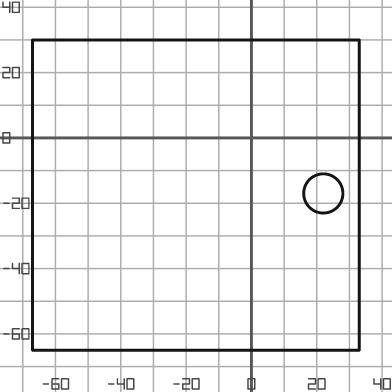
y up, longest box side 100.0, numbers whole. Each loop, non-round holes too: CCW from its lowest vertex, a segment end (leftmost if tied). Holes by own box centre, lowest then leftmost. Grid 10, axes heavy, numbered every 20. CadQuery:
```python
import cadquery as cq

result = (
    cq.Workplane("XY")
    .moveTo(-67.0, -65.0)
    .lineTo(33.0, -65.0)
    .lineTo(33.0, 30.0)
    .lineTo(-67.0, 30.0)
    .close()
    .moveTo(22.0, -17.0)
    .circle(6.0)
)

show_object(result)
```